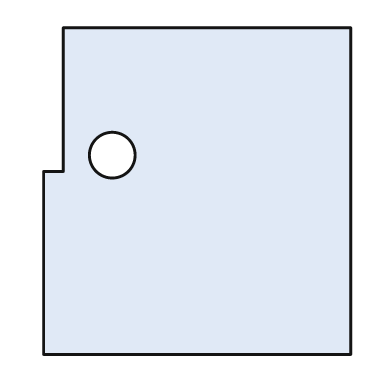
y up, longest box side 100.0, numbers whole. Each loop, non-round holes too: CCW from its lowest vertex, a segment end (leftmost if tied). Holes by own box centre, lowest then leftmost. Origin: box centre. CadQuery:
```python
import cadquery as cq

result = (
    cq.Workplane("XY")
    .moveTo(-47.0, -50.0)
    .lineTo(47.0, -50.0)
    .lineTo(47.0, 50.0)
    .lineTo(-41.0, 50.0)
    .lineTo(-41.0, 6.0)
    .lineTo(-47.0, 6.0)
    .close()
    .moveTo(-26.0, 11.0)
    .circle(7.0)
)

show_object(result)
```